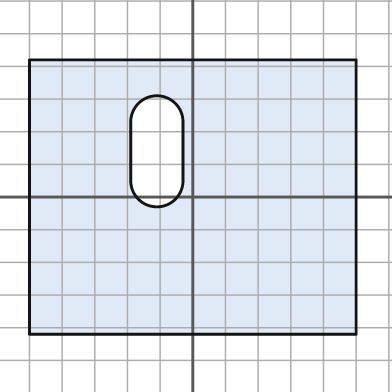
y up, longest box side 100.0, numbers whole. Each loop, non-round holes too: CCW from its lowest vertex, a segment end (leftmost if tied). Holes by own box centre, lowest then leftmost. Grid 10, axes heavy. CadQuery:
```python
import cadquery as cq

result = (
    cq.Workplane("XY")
    .moveTo(-50.0, -42.0)
    .lineTo(50.0, -42.0)
    .lineTo(50.0, 42.0)
    .lineTo(-50.0, 42.0)
    .close()
    .moveTo(-19.0, 5.0)
    .threePointArc((-11.0, -3.0), (-3.0, 5.0))
    .lineTo(-3.0, 23.0)
    .threePointArc((-11.0, 31.0), (-19.0, 23.0))
    .close()
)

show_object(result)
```